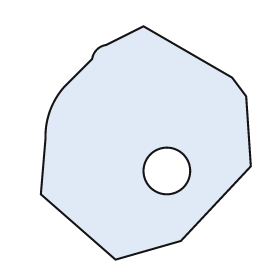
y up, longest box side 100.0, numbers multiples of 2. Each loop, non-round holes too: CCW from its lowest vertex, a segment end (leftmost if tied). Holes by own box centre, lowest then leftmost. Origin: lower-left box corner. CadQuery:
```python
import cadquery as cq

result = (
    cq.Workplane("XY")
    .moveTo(32.0, 0.0)
    .lineTo(60.0, 8.0)
    .lineTo(90.0, 40.0)
    .lineTo(88.0, 70.0)
    .lineTo(82.0, 78.0)
    .lineTo(44.0, 100.0)
    .lineTo(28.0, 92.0)
    .threePointArc((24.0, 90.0), (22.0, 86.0))
    .lineTo(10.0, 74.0)
    .threePointArc((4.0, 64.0), (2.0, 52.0))
    .lineTo(0.0, 28.0)
    .close()
    .moveTo(54.0, 38.0)
    .circle(10.0)
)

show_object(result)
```